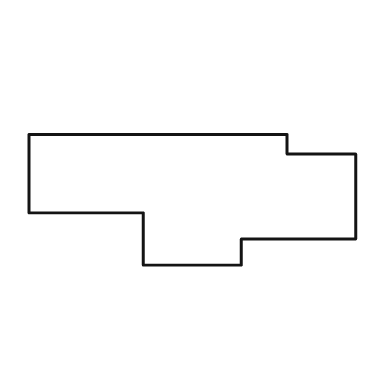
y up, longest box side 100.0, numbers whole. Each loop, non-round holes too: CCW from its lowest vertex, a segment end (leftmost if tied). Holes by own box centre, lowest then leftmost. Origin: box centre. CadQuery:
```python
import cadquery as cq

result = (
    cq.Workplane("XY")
    .moveTo(-15.0, -20.0)
    .lineTo(15.0, -20.0)
    .lineTo(15.0, -12.0)
    .lineTo(50.0, -12.0)
    .lineTo(50.0, 14.0)
    .lineTo(29.0, 14.0)
    .lineTo(29.0, 20.0)
    .lineTo(-50.0, 20.0)
    .lineTo(-50.0, -4.0)
    .lineTo(-15.0, -4.0)
    .close()
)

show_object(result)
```